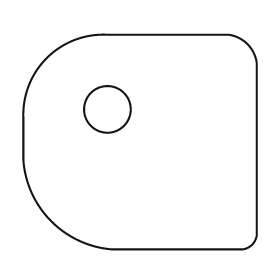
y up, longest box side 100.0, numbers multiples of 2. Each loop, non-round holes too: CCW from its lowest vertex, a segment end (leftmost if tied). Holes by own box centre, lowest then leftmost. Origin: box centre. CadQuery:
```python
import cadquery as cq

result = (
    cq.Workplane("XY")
    .moveTo(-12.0, -46.0)
    .lineTo(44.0, -46.0)
    .threePointArc((48.0, -44.0), (50.0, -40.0))
    .lineTo(50.0, 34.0)
    .threePointArc((46.0, 42.0), (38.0, 46.0))
    .lineTo(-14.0, 46.0)
    .threePointArc((-40.0, 36.0), (-50.0, 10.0))
    .lineTo(-50.0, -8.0)
    .threePointArc((-38.0, -34.0), (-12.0, -46.0))
    .close()
    .moveTo(-14.0, 14.0)
    .circle(10.0)
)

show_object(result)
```